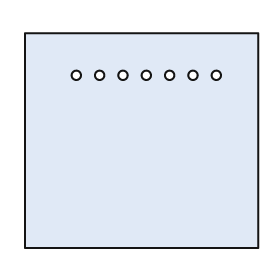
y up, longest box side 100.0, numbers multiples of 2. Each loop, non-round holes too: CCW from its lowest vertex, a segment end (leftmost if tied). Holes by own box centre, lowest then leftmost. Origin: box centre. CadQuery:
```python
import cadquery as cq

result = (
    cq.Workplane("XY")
    .moveTo(-50.0, -46.0)
    .lineTo(50.0, -46.0)
    .lineTo(50.0, 46.0)
    .lineTo(-50.0, 46.0)
    .close()
    .moveTo(-28.0, 28.0)
    .circle(2.0)
    .moveTo(-18.0, 28.0)
    .circle(2.0)
    .moveTo(-8.0, 28.0)
    .circle(2.0)
    .moveTo(2.0, 28.0)
    .circle(2.0)
    .moveTo(12.0, 28.0)
    .circle(2.0)
    .moveTo(22.0, 28.0)
    .circle(2.0)
    .moveTo(32.0, 28.0)
    .circle(2.0)
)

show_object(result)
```